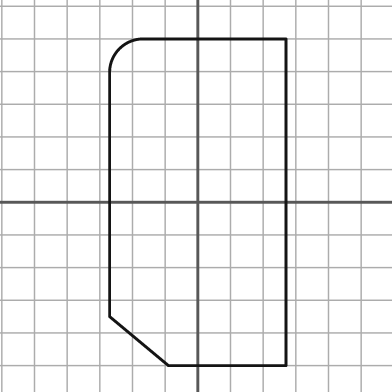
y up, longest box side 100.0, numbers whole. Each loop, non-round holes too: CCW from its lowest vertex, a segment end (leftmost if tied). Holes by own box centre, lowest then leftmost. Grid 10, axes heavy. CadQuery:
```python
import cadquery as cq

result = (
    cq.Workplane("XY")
    .moveTo(-9.0, -50.0)
    .lineTo(27.0, -50.0)
    .lineTo(27.0, 50.0)
    .lineTo(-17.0, 50.0)
    .threePointArc((-24.0, 47.0), (-27.0, 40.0))
    .lineTo(-27.0, -35.0)
    .close()
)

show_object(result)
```